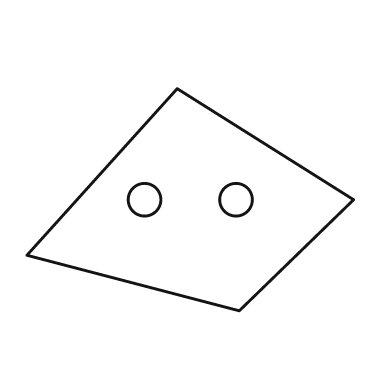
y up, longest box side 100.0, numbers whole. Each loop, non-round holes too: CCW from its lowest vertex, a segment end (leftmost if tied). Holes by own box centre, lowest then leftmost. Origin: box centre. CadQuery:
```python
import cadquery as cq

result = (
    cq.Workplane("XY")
    .moveTo(15.0, -34.0)
    .lineTo(50.0, 0.0)
    .lineTo(-4.0, 34.0)
    .lineTo(-50.0, -17.0)
    .close()
    .moveTo(-14.0, 0.0)
    .circle(5.0)
    .moveTo(14.0, 0.0)
    .circle(5.0)
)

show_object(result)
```